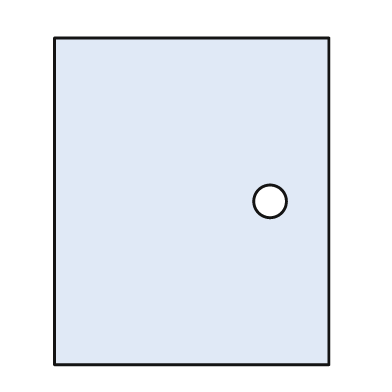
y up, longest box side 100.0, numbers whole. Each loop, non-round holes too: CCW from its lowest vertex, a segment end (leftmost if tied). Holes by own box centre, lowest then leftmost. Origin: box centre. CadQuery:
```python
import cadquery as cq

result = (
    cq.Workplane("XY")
    .moveTo(-42.0, -50.0)
    .lineTo(42.0, -50.0)
    .lineTo(42.0, 50.0)
    .lineTo(-42.0, 50.0)
    .close()
    .moveTo(24.0, 0.0)
    .circle(5.0)
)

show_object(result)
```